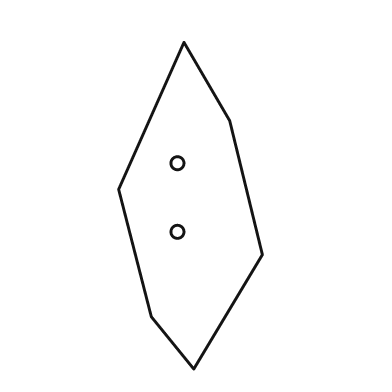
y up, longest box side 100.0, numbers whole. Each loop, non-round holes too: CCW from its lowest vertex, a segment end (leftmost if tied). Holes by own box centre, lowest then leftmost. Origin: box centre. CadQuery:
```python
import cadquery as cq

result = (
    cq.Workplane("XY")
    .moveTo(1.0, -50.0)
    .lineTo(22.0, -15.0)
    .lineTo(12.0, 26.0)
    .lineTo(-2.0, 50.0)
    .lineTo(-22.0, 5.0)
    .lineTo(-12.0, -34.0)
    .close()
    .moveTo(-4.0, -8.0)
    .circle(2.0)
    .moveTo(-4.0, 13.0)
    .circle(2.0)
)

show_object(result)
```